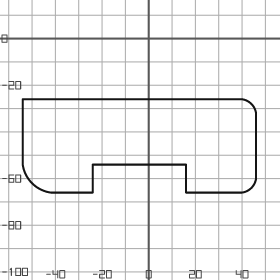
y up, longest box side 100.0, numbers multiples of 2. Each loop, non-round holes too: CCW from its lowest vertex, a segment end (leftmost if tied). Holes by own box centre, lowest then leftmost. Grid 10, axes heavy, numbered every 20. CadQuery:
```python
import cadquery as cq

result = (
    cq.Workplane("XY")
    .moveTo(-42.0, -66.0)
    .lineTo(-24.0, -66.0)
    .lineTo(-24.0, -54.0)
    .lineTo(16.0, -54.0)
    .lineTo(16.0, -66.0)
    .lineTo(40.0, -66.0)
    .threePointArc((44.0, -64.0), (46.0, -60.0))
    .lineTo(46.0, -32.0)
    .threePointArc((44.0, -28.0), (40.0, -26.0))
    .lineTo(-54.0, -26.0)
    .lineTo(-54.0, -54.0)
    .threePointArc((-50.0, -62.0), (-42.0, -66.0))
    .close()
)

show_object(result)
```